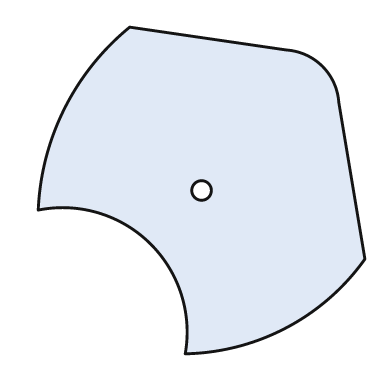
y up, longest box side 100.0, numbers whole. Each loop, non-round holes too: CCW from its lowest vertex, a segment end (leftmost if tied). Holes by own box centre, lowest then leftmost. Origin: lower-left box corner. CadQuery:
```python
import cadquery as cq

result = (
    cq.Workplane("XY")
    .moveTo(45.0, 0.0)
    .threePointArc((76.0, 8.0), (100.0, 29.0))
    .lineTo(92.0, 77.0)
    .threePointArc((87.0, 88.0), (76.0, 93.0))
    .lineTo(28.0, 100.0)
    .threePointArc((8.0, 75.0), (0.0, 44.0))
    .threePointArc((34.0, 34.0), (45.0, 0.0))
    .close()
    .moveTo(50.0, 50.0)
    .circle(3.0)
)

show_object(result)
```